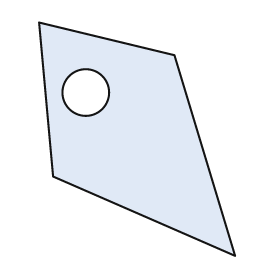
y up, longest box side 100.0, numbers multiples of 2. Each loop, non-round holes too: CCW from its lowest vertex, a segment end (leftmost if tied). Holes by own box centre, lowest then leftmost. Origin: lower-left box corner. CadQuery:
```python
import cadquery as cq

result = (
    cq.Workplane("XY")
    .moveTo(84.0, 0.0)
    .lineTo(58.0, 86.0)
    .lineTo(0.0, 100.0)
    .lineTo(6.0, 34.0)
    .close()
    .moveTo(20.0, 70.0)
    .circle(10.0)
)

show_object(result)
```